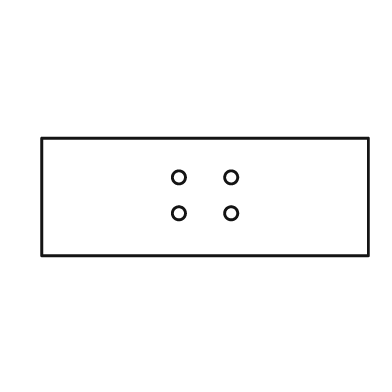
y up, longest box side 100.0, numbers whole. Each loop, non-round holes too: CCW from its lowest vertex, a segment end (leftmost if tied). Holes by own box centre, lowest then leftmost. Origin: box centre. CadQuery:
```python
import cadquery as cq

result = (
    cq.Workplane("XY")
    .moveTo(-50.0, -18.0)
    .lineTo(50.0, -18.0)
    .lineTo(50.0, 18.0)
    .lineTo(-50.0, 18.0)
    .close()
    .moveTo(-8.0, -5.0)
    .circle(2.0)
    .moveTo(8.0, -5.0)
    .circle(2.0)
    .moveTo(-8.0, 6.0)
    .circle(2.0)
    .moveTo(8.0, 6.0)
    .circle(2.0)
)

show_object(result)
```